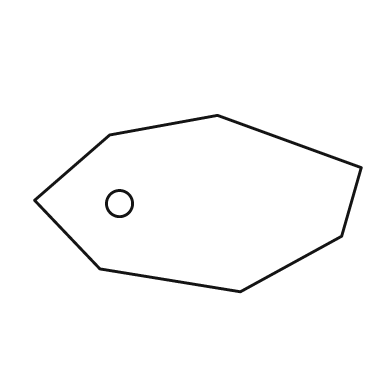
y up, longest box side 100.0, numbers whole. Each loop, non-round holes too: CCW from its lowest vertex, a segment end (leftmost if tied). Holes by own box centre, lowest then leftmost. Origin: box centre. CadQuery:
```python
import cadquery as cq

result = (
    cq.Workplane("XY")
    .moveTo(13.0, -27.0)
    .lineTo(44.0, -10.0)
    .lineTo(50.0, 11.0)
    .lineTo(6.0, 27.0)
    .lineTo(-27.0, 21.0)
    .lineTo(-50.0, 1.0)
    .lineTo(-30.0, -20.0)
    .close()
    .moveTo(-24.0, 0.0)
    .circle(4.0)
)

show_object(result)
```